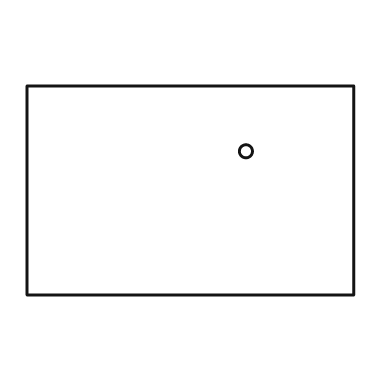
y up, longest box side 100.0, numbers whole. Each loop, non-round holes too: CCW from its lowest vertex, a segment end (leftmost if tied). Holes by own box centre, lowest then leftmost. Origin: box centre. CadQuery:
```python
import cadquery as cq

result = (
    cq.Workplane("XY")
    .moveTo(-50.0, -32.0)
    .lineTo(50.0, -32.0)
    .lineTo(50.0, 32.0)
    .lineTo(-50.0, 32.0)
    .close()
    .moveTo(17.0, 12.0)
    .circle(2.0)
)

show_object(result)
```